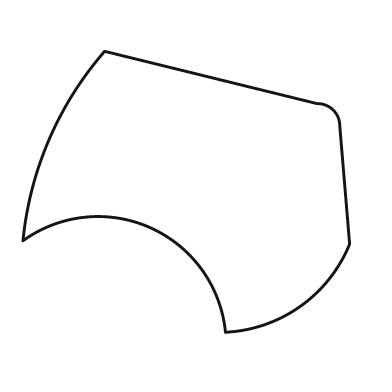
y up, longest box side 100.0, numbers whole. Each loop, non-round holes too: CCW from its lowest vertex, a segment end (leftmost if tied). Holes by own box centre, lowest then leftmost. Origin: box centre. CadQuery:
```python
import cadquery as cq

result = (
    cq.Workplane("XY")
    .moveTo(12.0, -43.0)
    .threePointArc((35.0, -35.0), (50.0, -16.0))
    .lineTo(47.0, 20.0)
    .threePointArc((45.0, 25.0), (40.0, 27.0))
    .lineTo(-25.0, 43.0)
    .threePointArc((-42.0, 16.0), (-50.0, -15.0))
    .threePointArc((-11.0, -11.0), (12.0, -43.0))
    .close()
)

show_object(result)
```